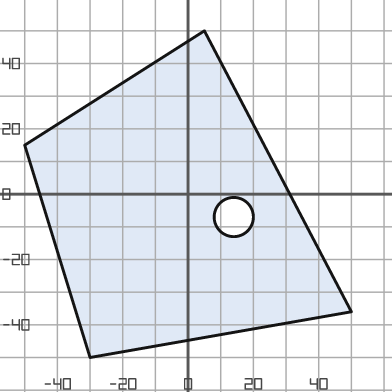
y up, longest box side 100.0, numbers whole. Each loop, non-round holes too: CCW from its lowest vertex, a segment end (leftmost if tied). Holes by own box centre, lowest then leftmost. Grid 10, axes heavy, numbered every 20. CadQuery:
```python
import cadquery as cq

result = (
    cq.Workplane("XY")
    .moveTo(-30.0, -50.0)
    .lineTo(50.0, -36.0)
    .lineTo(5.0, 50.0)
    .lineTo(-50.0, 15.0)
    .close()
    .moveTo(14.0, -7.0)
    .circle(6.0)
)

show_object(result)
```